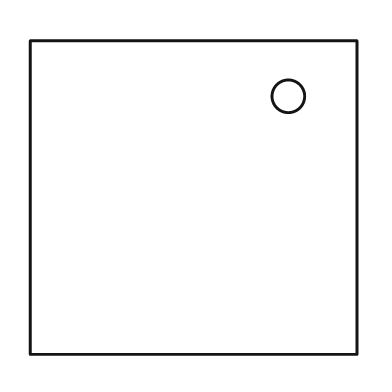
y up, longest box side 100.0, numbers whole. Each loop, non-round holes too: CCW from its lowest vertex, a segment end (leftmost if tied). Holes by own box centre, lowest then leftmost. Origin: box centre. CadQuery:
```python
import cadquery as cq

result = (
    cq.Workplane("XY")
    .moveTo(-50.0, -48.0)
    .lineTo(50.0, -48.0)
    .lineTo(50.0, 48.0)
    .lineTo(-50.0, 48.0)
    .close()
    .moveTo(29.0, 31.0)
    .circle(5.0)
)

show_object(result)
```